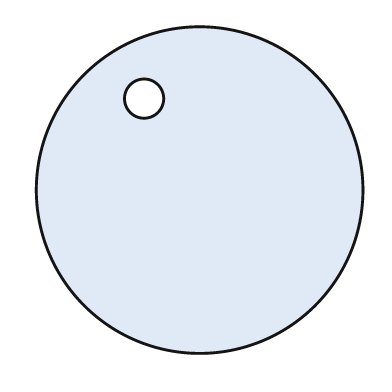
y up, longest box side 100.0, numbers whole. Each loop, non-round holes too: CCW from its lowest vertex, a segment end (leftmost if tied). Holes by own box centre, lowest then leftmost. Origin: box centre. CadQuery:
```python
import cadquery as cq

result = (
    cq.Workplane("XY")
    .moveTo(0.0, 0.0)
    .circle(50.0)
    .moveTo(-17.0, 28.0)
    .circle(6.0)
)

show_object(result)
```